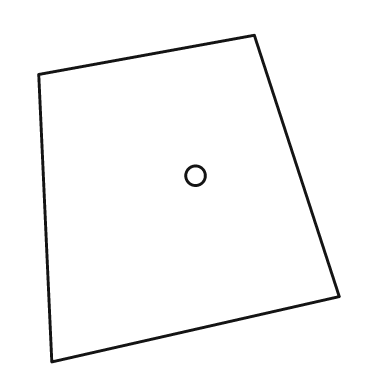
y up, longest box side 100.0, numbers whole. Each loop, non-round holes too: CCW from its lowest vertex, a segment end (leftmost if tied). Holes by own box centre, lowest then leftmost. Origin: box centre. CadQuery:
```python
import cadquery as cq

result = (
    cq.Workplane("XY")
    .moveTo(-42.0, -50.0)
    .lineTo(46.0, -30.0)
    .lineTo(20.0, 50.0)
    .lineTo(-46.0, 38.0)
    .close()
    .moveTo(2.0, 7.0)
    .circle(3.0)
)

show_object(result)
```